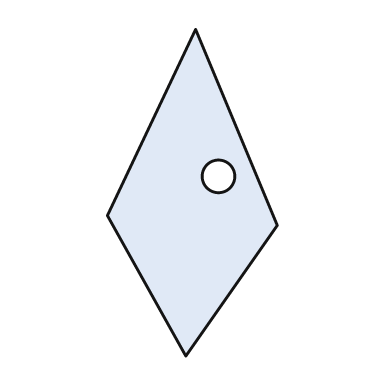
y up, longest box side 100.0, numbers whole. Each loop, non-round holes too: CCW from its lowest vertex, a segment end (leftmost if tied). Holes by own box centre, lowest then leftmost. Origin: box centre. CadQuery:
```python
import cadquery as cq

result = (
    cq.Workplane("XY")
    .moveTo(-2.0, -50.0)
    .lineTo(26.0, -10.0)
    .lineTo(1.0, 50.0)
    .lineTo(-26.0, -7.0)
    .close()
    .moveTo(8.0, 5.0)
    .circle(5.0)
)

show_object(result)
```